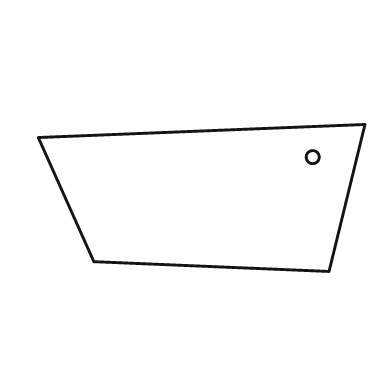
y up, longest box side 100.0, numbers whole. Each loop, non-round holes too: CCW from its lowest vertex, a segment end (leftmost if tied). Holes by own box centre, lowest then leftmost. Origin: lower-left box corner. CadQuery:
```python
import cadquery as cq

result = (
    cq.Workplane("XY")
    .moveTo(89.0, 0.0)
    .lineTo(100.0, 45.0)
    .lineTo(0.0, 41.0)
    .lineTo(17.0, 3.0)
    .close()
    .moveTo(84.0, 35.0)
    .circle(2.0)
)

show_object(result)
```